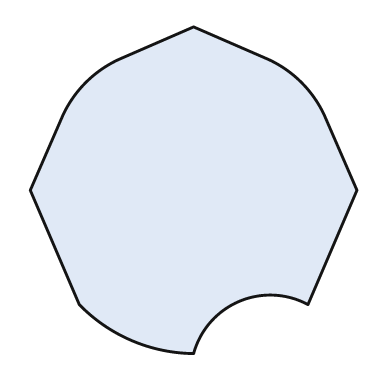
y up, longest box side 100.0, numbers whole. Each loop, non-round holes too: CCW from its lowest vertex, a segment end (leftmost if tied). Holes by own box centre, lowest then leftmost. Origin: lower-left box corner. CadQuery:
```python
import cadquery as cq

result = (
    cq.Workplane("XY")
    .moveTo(50.0, 0.0)
    .threePointArc((64.0, 16.0), (85.0, 15.0))
    .lineTo(100.0, 50.0)
    .lineTo(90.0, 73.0)
    .threePointArc((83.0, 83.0), (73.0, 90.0))
    .lineTo(50.0, 100.0)
    .lineTo(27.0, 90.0)
    .threePointArc((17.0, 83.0), (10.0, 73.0))
    .lineTo(0.0, 50.0)
    .lineTo(15.0, 15.0)
    .threePointArc((31.0, 4.0), (50.0, 0.0))
    .close()
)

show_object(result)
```